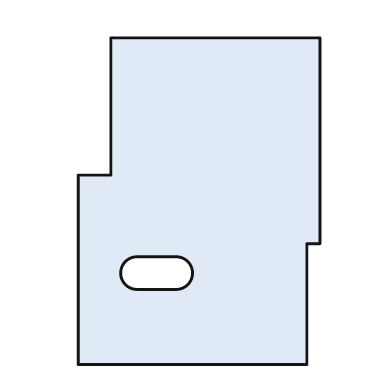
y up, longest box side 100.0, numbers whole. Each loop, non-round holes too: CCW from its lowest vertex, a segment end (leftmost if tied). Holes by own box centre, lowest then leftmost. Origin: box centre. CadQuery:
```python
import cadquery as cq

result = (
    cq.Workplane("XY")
    .moveTo(-37.0, -50.0)
    .lineTo(33.0, -50.0)
    .lineTo(33.0, -13.0)
    .lineTo(37.0, -13.0)
    .lineTo(37.0, 50.0)
    .lineTo(-27.0, 50.0)
    .lineTo(-27.0, 8.0)
    .lineTo(-37.0, 8.0)
    .close()
    .moveTo(-19.0, -27.0)
    .lineTo(-7.0, -27.0)
    .threePointArc((-2.0, -22.0), (-7.0, -17.0))
    .lineTo(-19.0, -17.0)
    .threePointArc((-24.0, -22.0), (-19.0, -27.0))
    .close()
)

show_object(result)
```